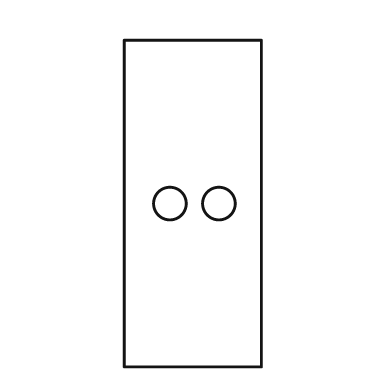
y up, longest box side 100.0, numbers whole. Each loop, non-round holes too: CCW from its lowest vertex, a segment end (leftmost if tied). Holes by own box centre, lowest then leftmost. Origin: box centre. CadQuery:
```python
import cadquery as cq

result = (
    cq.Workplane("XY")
    .moveTo(-21.0, -50.0)
    .lineTo(21.0, -50.0)
    .lineTo(21.0, 50.0)
    .lineTo(-21.0, 50.0)
    .close()
    .moveTo(-7.0, 0.0)
    .circle(5.0)
    .moveTo(8.0, 0.0)
    .circle(5.0)
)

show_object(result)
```